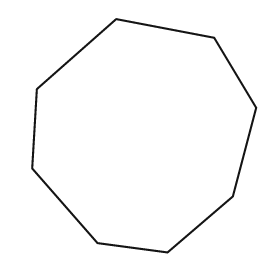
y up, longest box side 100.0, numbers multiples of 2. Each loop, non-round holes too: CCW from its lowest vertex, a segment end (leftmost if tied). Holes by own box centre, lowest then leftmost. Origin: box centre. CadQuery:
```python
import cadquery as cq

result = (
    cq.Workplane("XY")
    .moveTo(10.0, -50.0)
    .lineTo(38.0, -26.0)
    .lineTo(48.0, 12.0)
    .lineTo(30.0, 42.0)
    .lineTo(-12.0, 50.0)
    .lineTo(-46.0, 20.0)
    .lineTo(-48.0, -14.0)
    .lineTo(-20.0, -46.0)
    .close()
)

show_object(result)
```